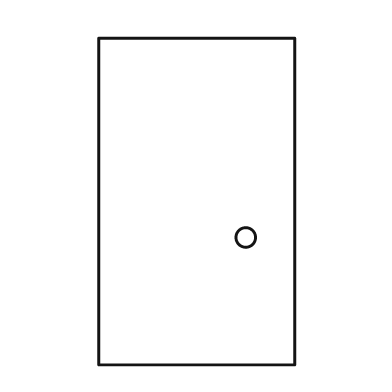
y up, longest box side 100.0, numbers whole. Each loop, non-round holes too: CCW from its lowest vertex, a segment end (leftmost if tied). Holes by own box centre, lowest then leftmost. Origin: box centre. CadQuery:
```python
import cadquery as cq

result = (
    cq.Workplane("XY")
    .moveTo(-30.0, -50.0)
    .lineTo(30.0, -50.0)
    .lineTo(30.0, 50.0)
    .lineTo(-30.0, 50.0)
    .close()
    .moveTo(15.0, -11.0)
    .circle(3.0)
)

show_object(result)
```